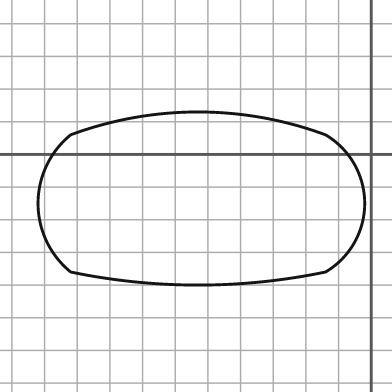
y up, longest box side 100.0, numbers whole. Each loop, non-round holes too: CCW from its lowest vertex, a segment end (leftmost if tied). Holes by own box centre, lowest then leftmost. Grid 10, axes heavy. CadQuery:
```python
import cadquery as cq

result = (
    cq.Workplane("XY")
    .moveTo(-92.0, -36.0)
    .threePointArc((-53.0, -40.0), (-14.0, -36.0))
    .threePointArc((-2.0, -15.0), (-14.0, 6.0))
    .threePointArc((-53.0, 13.0), (-92.0, 6.0))
    .threePointArc((-102.0, -15.0), (-92.0, -36.0))
    .close()
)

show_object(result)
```